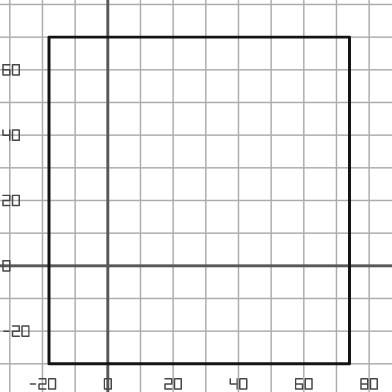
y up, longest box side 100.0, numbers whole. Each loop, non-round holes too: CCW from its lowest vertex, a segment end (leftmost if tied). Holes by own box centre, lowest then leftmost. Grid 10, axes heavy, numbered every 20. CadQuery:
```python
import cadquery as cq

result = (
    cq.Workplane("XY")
    .moveTo(-18.0, -30.0)
    .lineTo(74.0, -30.0)
    .lineTo(74.0, 70.0)
    .lineTo(-18.0, 70.0)
    .close()
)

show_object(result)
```